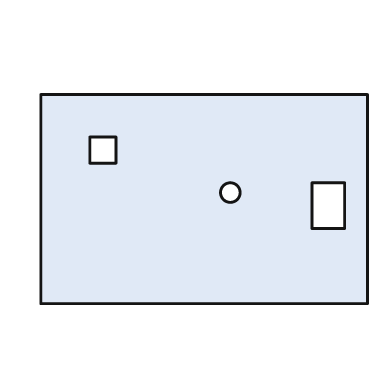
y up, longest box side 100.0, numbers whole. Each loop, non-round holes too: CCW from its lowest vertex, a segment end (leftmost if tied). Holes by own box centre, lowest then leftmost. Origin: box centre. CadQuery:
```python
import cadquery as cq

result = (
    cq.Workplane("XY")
    .moveTo(-50.0, -32.0)
    .lineTo(50.0, -32.0)
    .lineTo(50.0, 32.0)
    .lineTo(-50.0, 32.0)
    .close()
    .moveTo(33.0, -9.0)
    .lineTo(43.0, -9.0)
    .lineTo(43.0, 5.0)
    .lineTo(33.0, 5.0)
    .close()
    .moveTo(8.0, 2.0)
    .circle(3.0)
    .moveTo(-35.0, 11.0)
    .lineTo(-27.0, 11.0)
    .lineTo(-27.0, 19.0)
    .lineTo(-35.0, 19.0)
    .close()
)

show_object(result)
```